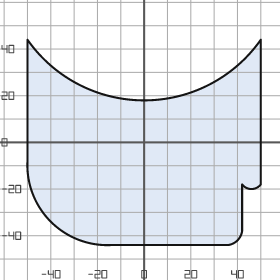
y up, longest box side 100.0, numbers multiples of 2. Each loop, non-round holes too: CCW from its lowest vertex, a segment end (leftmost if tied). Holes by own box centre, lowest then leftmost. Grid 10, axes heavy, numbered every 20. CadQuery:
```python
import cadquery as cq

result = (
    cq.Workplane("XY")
    .moveTo(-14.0, -44.0)
    .lineTo(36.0, -44.0)
    .threePointArc((40.0, -42.0), (42.0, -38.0))
    .lineTo(42.0, -18.0)
    .threePointArc((46.0, -20.0), (50.0, -18.0))
    .lineTo(50.0, 44.0)
    .threePointArc((0.0, 18.0), (-50.0, 44.0))
    .lineTo(-50.0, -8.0)
    .threePointArc((-40.0, -34.0), (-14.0, -44.0))
    .close()
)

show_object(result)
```